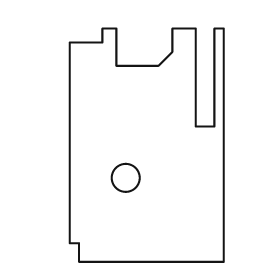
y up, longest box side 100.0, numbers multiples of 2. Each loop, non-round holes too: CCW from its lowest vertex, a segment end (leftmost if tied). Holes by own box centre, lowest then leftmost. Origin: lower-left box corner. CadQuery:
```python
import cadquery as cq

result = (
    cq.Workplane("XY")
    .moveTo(4.0, 0.0)
    .lineTo(66.0, 0.0)
    .lineTo(66.0, 100.0)
    .lineTo(62.0, 100.0)
    .lineTo(62.0, 58.0)
    .lineTo(54.0, 58.0)
    .lineTo(54.0, 100.0)
    .lineTo(44.0, 100.0)
    .lineTo(44.0, 90.0)
    .lineTo(38.0, 84.0)
    .lineTo(20.0, 84.0)
    .lineTo(20.0, 100.0)
    .lineTo(14.0, 100.0)
    .lineTo(14.0, 94.0)
    .lineTo(0.0, 94.0)
    .lineTo(0.0, 8.0)
    .lineTo(4.0, 8.0)
    .close()
    .moveTo(24.0, 36.0)
    .circle(6.0)
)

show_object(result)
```